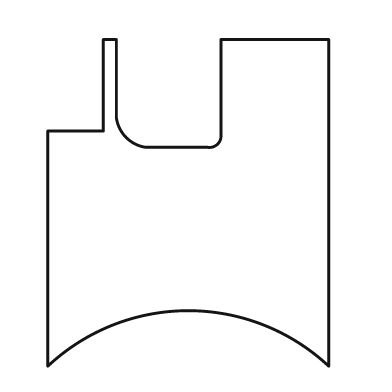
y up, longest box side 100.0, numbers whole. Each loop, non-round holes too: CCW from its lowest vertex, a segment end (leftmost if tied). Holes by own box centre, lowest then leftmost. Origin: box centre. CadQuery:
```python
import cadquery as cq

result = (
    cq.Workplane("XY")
    .moveTo(-43.0, -50.0)
    .threePointArc((0.0, -33.0), (43.0, -50.0))
    .lineTo(43.0, 50.0)
    .lineTo(10.0, 50.0)
    .lineTo(10.0, 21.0)
    .threePointArc((9.0, 18.0), (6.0, 17.0))
    .lineTo(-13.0, 17.0)
    .threePointArc((-19.0, 20.0), (-22.0, 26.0))
    .lineTo(-22.0, 50.0)
    .lineTo(-26.0, 50.0)
    .lineTo(-26.0, 22.0)
    .lineTo(-43.0, 22.0)
    .close()
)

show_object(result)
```